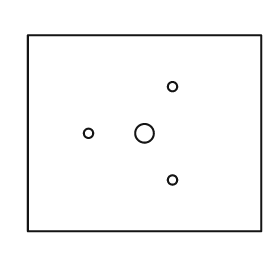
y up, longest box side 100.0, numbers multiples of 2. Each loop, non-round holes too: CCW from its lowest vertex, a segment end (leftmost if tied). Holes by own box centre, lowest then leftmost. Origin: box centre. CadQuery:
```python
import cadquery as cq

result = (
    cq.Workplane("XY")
    .moveTo(-50.0, -42.0)
    .lineTo(50.0, -42.0)
    .lineTo(50.0, 42.0)
    .lineTo(-50.0, 42.0)
    .close()
    .moveTo(12.0, -20.0)
    .circle(2.0)
    .moveTo(-24.0, 0.0)
    .circle(2.0)
    .moveTo(0.0, 0.0)
    .circle(4.0)
    .moveTo(12.0, 20.0)
    .circle(2.0)
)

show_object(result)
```